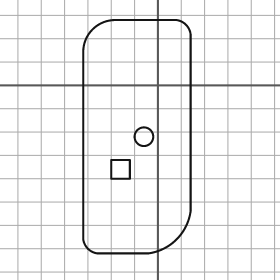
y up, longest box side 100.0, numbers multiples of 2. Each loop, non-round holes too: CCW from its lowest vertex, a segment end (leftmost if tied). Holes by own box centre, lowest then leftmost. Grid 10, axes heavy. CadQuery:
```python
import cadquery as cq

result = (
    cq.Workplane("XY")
    .moveTo(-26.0, -72.0)
    .lineTo(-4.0, -72.0)
    .threePointArc((8.0, -66.0), (14.0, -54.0))
    .lineTo(14.0, 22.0)
    .threePointArc((12.0, 26.0), (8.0, 28.0))
    .lineTo(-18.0, 28.0)
    .threePointArc((-28.0, 24.0), (-32.0, 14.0))
    .lineTo(-32.0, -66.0)
    .threePointArc((-30.0, -70.0), (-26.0, -72.0))
    .close()
    .moveTo(-20.0, -40.0)
    .lineTo(-12.0, -40.0)
    .lineTo(-12.0, -32.0)
    .lineTo(-20.0, -32.0)
    .close()
    .moveTo(-6.0, -22.0)
    .circle(4.0)
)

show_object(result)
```